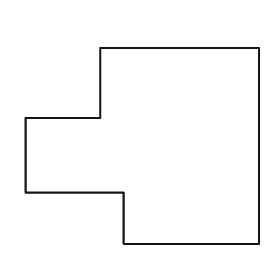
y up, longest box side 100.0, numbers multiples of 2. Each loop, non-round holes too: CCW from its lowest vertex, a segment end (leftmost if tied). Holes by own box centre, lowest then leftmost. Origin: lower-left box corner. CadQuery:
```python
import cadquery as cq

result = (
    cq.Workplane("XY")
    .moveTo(42.0, 0.0)
    .lineTo(100.0, 0.0)
    .lineTo(100.0, 84.0)
    .lineTo(32.0, 84.0)
    .lineTo(32.0, 54.0)
    .lineTo(0.0, 54.0)
    .lineTo(0.0, 22.0)
    .lineTo(42.0, 22.0)
    .close()
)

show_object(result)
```